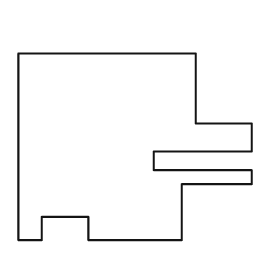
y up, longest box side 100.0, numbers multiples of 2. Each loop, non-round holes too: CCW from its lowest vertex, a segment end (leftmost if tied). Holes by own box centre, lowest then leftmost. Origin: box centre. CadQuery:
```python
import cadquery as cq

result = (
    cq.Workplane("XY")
    .moveTo(-50.0, -40.0)
    .lineTo(-40.0, -40.0)
    .lineTo(-40.0, -30.0)
    .lineTo(-20.0, -30.0)
    .lineTo(-20.0, -40.0)
    .lineTo(20.0, -40.0)
    .lineTo(20.0, -16.0)
    .lineTo(50.0, -16.0)
    .lineTo(50.0, -10.0)
    .lineTo(8.0, -10.0)
    .lineTo(8.0, -2.0)
    .lineTo(50.0, -2.0)
    .lineTo(50.0, 10.0)
    .lineTo(26.0, 10.0)
    .lineTo(26.0, 40.0)
    .lineTo(-50.0, 40.0)
    .close()
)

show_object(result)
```